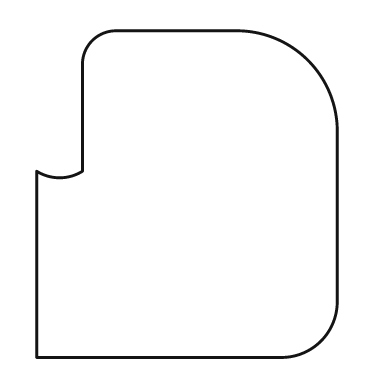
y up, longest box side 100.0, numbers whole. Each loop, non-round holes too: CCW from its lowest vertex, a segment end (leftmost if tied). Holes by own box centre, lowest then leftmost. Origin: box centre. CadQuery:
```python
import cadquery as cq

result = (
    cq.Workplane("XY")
    .moveTo(-46.0, -50.0)
    .lineTo(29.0, -50.0)
    .threePointArc((41.0, -45.0), (46.0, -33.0))
    .lineTo(46.0, 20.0)
    .threePointArc((37.0, 41.0), (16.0, 50.0))
    .lineTo(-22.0, 50.0)
    .threePointArc((-29.0, 47.0), (-32.0, 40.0))
    .lineTo(-32.0, 7.0)
    .threePointArc((-39.0, 5.0), (-46.0, 7.0))
    .close()
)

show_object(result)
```